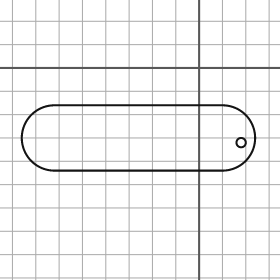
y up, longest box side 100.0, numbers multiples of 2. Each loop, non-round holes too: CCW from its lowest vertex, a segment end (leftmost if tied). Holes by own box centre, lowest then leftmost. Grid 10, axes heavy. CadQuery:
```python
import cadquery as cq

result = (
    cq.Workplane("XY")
    .moveTo(-62.0, -44.0)
    .lineTo(10.0, -44.0)
    .threePointArc((24.0, -30.0), (10.0, -16.0))
    .lineTo(-62.0, -16.0)
    .threePointArc((-76.0, -30.0), (-62.0, -44.0))
    .close()
    .moveTo(18.0, -32.0)
    .circle(2.0)
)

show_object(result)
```